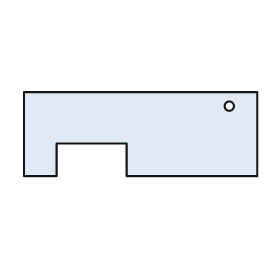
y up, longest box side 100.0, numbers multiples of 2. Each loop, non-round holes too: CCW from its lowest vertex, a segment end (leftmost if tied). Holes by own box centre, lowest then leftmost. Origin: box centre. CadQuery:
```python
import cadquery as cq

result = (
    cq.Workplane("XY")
    .moveTo(-50.0, -18.0)
    .lineTo(-36.0, -18.0)
    .lineTo(-36.0, -4.0)
    .lineTo(-6.0, -4.0)
    .lineTo(-6.0, -18.0)
    .lineTo(50.0, -18.0)
    .lineTo(50.0, 18.0)
    .lineTo(-50.0, 18.0)
    .close()
    .moveTo(38.0, 12.0)
    .circle(2.0)
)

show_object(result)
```